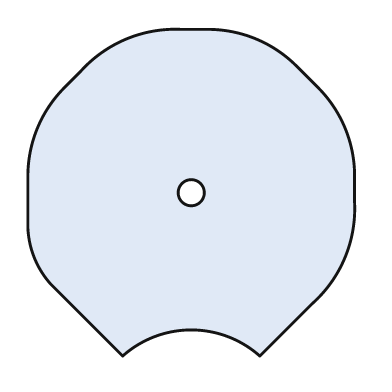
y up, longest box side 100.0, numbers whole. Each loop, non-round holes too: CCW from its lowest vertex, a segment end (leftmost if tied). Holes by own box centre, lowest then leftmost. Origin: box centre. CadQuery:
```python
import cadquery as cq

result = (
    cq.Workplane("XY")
    .moveTo(-21.0, -50.0)
    .threePointArc((0.0, -42.0), (21.0, -50.0))
    .lineTo(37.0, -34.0)
    .threePointArc((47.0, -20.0), (50.0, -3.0))
    .lineTo(50.0, 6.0)
    .threePointArc((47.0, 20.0), (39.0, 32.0))
    .lineTo(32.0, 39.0)
    .threePointArc((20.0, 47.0), (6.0, 50.0))
    .lineTo(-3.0, 50.0)
    .threePointArc((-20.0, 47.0), (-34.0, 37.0))
    .lineTo(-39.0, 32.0)
    .threePointArc((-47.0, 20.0), (-50.0, 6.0))
    .lineTo(-50.0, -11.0)
    .threePointArc((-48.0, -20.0), (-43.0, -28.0))
    .close()
    .moveTo(0.0, 0.0)
    .circle(4.0)
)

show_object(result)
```